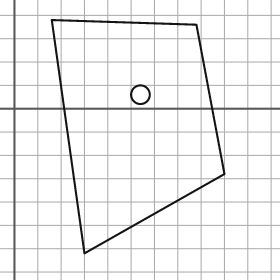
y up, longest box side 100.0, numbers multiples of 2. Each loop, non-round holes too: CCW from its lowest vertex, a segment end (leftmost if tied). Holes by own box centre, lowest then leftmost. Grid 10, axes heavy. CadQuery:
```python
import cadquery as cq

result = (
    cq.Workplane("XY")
    .moveTo(30.0, -62.0)
    .lineTo(90.0, -28.0)
    .lineTo(78.0, 36.0)
    .lineTo(16.0, 38.0)
    .close()
    .moveTo(54.0, 6.0)
    .circle(4.0)
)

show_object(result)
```